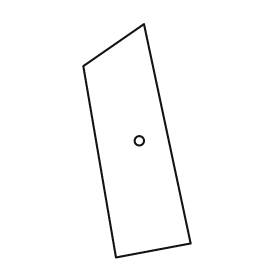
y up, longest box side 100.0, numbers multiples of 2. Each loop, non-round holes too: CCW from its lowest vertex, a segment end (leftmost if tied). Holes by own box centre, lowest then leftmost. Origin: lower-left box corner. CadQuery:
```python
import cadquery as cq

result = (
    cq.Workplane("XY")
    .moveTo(14.0, 0.0)
    .lineTo(46.0, 6.0)
    .lineTo(26.0, 100.0)
    .lineTo(0.0, 82.0)
    .close()
    .moveTo(24.0, 50.0)
    .circle(2.0)
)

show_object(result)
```